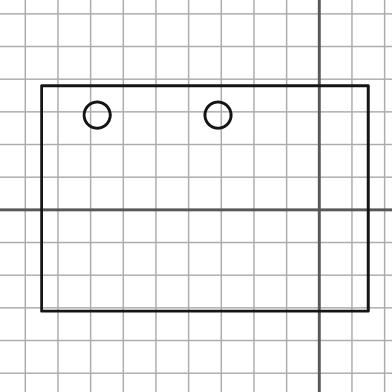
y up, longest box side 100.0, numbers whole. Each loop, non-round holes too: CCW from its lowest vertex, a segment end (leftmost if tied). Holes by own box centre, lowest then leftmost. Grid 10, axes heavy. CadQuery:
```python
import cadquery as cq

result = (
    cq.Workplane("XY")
    .moveTo(-85.0, -31.0)
    .lineTo(15.0, -31.0)
    .lineTo(15.0, 38.0)
    .lineTo(-85.0, 38.0)
    .close()
    .moveTo(-68.0, 29.0)
    .circle(4.0)
    .moveTo(-31.0, 29.0)
    .circle(4.0)
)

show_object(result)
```